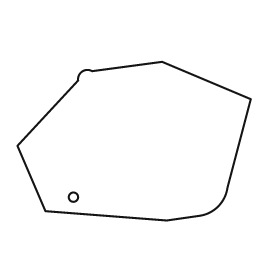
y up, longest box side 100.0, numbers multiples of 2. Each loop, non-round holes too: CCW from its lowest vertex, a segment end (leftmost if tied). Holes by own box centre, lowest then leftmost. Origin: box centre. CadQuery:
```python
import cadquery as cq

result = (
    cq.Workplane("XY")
    .moveTo(14.0, -34.0)
    .lineTo(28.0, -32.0)
    .threePointArc((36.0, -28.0), (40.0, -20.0))
    .lineTo(50.0, 18.0)
    .lineTo(12.0, 34.0)
    .lineTo(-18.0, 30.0)
    .threePointArc((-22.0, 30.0), (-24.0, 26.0))
    .lineTo(-50.0, -2.0)
    .lineTo(-38.0, -30.0)
    .close()
    .moveTo(-26.0, -24.0)
    .circle(2.0)
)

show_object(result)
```